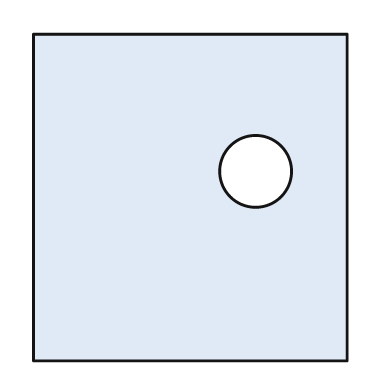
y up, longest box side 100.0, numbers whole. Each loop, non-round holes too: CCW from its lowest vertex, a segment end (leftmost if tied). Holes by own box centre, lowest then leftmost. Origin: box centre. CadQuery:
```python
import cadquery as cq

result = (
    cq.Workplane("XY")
    .moveTo(-48.0, -50.0)
    .lineTo(48.0, -50.0)
    .lineTo(48.0, 50.0)
    .lineTo(-48.0, 50.0)
    .close()
    .moveTo(20.0, 8.0)
    .circle(11.0)
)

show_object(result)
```